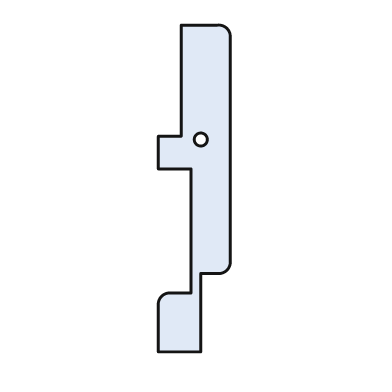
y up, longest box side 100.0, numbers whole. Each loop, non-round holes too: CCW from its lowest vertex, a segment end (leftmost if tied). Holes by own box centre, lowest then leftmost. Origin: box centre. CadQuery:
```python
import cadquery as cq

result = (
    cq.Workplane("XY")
    .moveTo(-11.0, -50.0)
    .lineTo(2.0, -50.0)
    .lineTo(2.0, -26.0)
    .lineTo(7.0, -26.0)
    .threePointArc((10.0, -25.0), (11.0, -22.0))
    .lineTo(11.0, 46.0)
    .threePointArc((10.0, 49.0), (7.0, 50.0))
    .lineTo(-4.0, 50.0)
    .lineTo(-4.0, 16.0)
    .lineTo(-11.0, 16.0)
    .lineTo(-11.0, 6.0)
    .lineTo(-1.0, 6.0)
    .lineTo(-1.0, -32.0)
    .lineTo(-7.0, -32.0)
    .threePointArc((-10.0, -33.0), (-11.0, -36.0))
    .close()
    .moveTo(2.0, 15.0)
    .circle(2.0)
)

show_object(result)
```